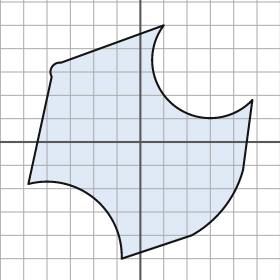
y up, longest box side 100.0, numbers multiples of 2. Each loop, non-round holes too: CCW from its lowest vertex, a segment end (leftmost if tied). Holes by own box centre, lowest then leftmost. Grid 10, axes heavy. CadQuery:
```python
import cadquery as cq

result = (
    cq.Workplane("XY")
    .moveTo(-8.0, -50.0)
    .lineTo(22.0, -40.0)
    .threePointArc((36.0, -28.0), (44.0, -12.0))
    .lineTo(48.0, 18.0)
    .threePointArc((14.0, 16.0), (10.0, 50.0))
    .lineTo(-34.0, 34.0)
    .threePointArc((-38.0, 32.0), (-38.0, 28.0))
    .lineTo(-48.0, -18.0)
    .threePointArc((-20.0, -24.0), (-8.0, -50.0))
    .close()
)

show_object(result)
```